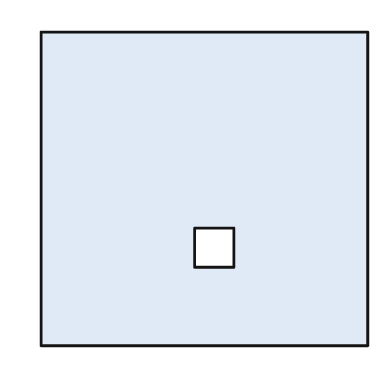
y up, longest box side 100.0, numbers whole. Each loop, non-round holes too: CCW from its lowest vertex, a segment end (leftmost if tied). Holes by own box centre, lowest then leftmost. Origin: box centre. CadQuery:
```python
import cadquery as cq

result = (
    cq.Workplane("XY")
    .moveTo(-50.0, -48.0)
    .lineTo(50.0, -48.0)
    .lineTo(50.0, 48.0)
    .lineTo(-50.0, 48.0)
    .close()
    .moveTo(-3.0, -24.0)
    .lineTo(9.0, -24.0)
    .lineTo(9.0, -12.0)
    .lineTo(-3.0, -12.0)
    .close()
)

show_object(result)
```